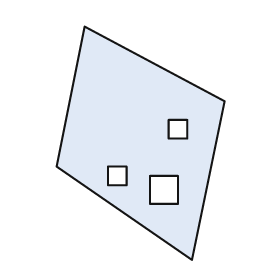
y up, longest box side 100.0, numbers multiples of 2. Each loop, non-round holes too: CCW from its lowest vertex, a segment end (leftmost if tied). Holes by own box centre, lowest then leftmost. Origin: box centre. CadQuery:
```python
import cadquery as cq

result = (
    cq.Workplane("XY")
    .moveTo(22.0, -50.0)
    .lineTo(36.0, 18.0)
    .lineTo(-24.0, 50.0)
    .lineTo(-36.0, -10.0)
    .close()
    .moveTo(4.0, -26.0)
    .lineTo(16.0, -26.0)
    .lineTo(16.0, -14.0)
    .lineTo(4.0, -14.0)
    .close()
    .moveTo(-14.0, -18.0)
    .lineTo(-6.0, -18.0)
    .lineTo(-6.0, -10.0)
    .lineTo(-14.0, -10.0)
    .close()
    .moveTo(12.0, 2.0)
    .lineTo(20.0, 2.0)
    .lineTo(20.0, 10.0)
    .lineTo(12.0, 10.0)
    .close()
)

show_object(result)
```